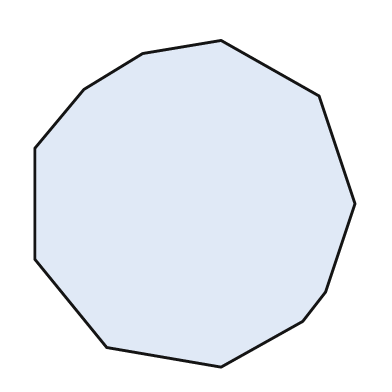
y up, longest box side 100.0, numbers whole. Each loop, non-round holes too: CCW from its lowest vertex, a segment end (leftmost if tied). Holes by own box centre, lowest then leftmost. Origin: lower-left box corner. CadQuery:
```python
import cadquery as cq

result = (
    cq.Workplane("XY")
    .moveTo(57.0, 0.0)
    .lineTo(82.0, 14.0)
    .lineTo(89.0, 23.0)
    .lineTo(98.0, 50.0)
    .lineTo(87.0, 83.0)
    .lineTo(57.0, 100.0)
    .lineTo(33.0, 96.0)
    .lineTo(15.0, 85.0)
    .lineTo(0.0, 67.0)
    .lineTo(0.0, 33.0)
    .lineTo(22.0, 6.0)
    .close()
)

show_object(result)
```